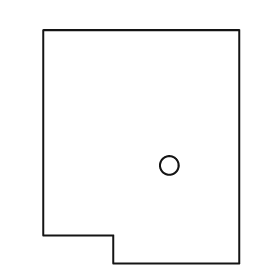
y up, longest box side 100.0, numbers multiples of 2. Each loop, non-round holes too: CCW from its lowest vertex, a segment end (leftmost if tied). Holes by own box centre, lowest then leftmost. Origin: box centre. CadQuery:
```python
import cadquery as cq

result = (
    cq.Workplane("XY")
    .moveTo(-12.0, -50.0)
    .lineTo(42.0, -50.0)
    .lineTo(42.0, 50.0)
    .lineTo(-42.0, 50.0)
    .lineTo(-42.0, -38.0)
    .lineTo(-12.0, -38.0)
    .close()
    .moveTo(12.0, -8.0)
    .circle(4.0)
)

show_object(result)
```